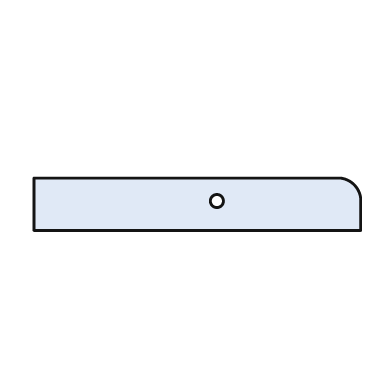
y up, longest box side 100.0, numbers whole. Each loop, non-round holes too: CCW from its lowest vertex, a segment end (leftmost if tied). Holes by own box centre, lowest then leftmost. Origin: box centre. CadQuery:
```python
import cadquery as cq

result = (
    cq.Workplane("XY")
    .moveTo(-50.0, -8.0)
    .lineTo(50.0, -8.0)
    .lineTo(50.0, 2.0)
    .threePointArc((48.0, 6.0), (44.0, 8.0))
    .lineTo(-50.0, 8.0)
    .close()
    .moveTo(6.0, 1.0)
    .circle(2.0)
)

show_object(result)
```